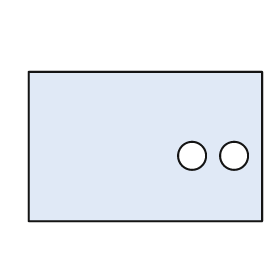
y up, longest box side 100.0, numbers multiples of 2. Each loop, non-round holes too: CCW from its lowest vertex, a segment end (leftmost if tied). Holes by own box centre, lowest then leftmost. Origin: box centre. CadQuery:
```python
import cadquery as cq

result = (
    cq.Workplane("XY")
    .moveTo(-50.0, -32.0)
    .lineTo(50.0, -32.0)
    .lineTo(50.0, 32.0)
    .lineTo(-50.0, 32.0)
    .close()
    .moveTo(20.0, -4.0)
    .circle(6.0)
    .moveTo(38.0, -4.0)
    .circle(6.0)
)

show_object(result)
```